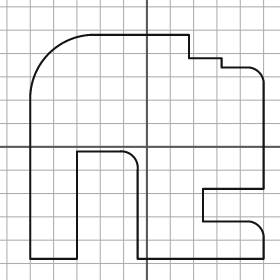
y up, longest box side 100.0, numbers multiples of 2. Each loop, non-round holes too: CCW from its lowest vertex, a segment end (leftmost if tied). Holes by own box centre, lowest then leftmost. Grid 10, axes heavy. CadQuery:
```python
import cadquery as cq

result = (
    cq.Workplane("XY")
    .moveTo(-50.0, -48.0)
    .lineTo(-30.0, -48.0)
    .lineTo(-30.0, -2.0)
    .lineTo(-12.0, -2.0)
    .threePointArc((-6.0, -4.0), (-4.0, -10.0))
    .lineTo(-4.0, -48.0)
    .lineTo(50.0, -48.0)
    .lineTo(50.0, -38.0)
    .threePointArc((48.0, -34.0), (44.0, -32.0))
    .lineTo(24.0, -32.0)
    .lineTo(24.0, -18.0)
    .lineTo(50.0, -18.0)
    .lineTo(50.0, 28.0)
    .threePointArc((48.0, 32.0), (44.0, 34.0))
    .lineTo(32.0, 34.0)
    .lineTo(32.0, 38.0)
    .lineTo(18.0, 38.0)
    .lineTo(18.0, 48.0)
    .lineTo(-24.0, 48.0)
    .threePointArc((-42.0, 40.0), (-50.0, 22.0))
    .close()
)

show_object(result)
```